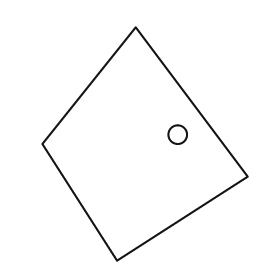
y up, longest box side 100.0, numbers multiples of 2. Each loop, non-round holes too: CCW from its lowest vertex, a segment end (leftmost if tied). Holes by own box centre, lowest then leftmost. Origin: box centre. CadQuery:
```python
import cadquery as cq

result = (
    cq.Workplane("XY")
    .moveTo(-12.0, -50.0)
    .lineTo(44.0, -14.0)
    .lineTo(-4.0, 50.0)
    .lineTo(-44.0, 0.0)
    .close()
    .moveTo(14.0, 4.0)
    .circle(4.0)
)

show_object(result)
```